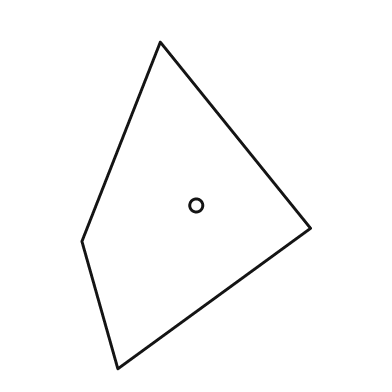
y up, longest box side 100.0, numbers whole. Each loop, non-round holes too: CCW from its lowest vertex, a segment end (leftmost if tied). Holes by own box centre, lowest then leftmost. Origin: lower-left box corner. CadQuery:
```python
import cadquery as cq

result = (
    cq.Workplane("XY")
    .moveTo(11.0, 0.0)
    .lineTo(70.0, 43.0)
    .lineTo(24.0, 100.0)
    .lineTo(0.0, 39.0)
    .close()
    .moveTo(35.0, 50.0)
    .circle(2.0)
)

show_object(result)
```